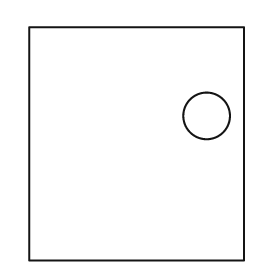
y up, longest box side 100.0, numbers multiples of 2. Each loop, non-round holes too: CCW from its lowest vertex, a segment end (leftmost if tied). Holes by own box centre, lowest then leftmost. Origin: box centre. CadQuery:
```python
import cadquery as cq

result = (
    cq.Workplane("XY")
    .moveTo(-46.0, -50.0)
    .lineTo(46.0, -50.0)
    .lineTo(46.0, 50.0)
    .lineTo(-46.0, 50.0)
    .close()
    .moveTo(30.0, 12.0)
    .circle(10.0)
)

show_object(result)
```